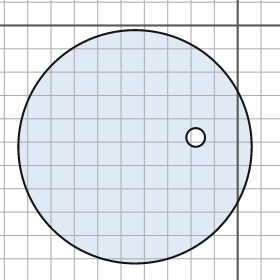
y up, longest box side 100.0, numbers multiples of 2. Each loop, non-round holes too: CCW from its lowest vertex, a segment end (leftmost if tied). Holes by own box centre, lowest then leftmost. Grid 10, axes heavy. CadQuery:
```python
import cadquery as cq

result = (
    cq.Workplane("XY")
    .moveTo(-44.0, -52.0)
    .circle(50.0)
    .moveTo(-18.0, -48.0)
    .circle(4.0)
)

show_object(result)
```